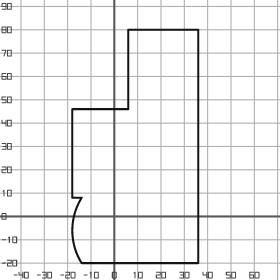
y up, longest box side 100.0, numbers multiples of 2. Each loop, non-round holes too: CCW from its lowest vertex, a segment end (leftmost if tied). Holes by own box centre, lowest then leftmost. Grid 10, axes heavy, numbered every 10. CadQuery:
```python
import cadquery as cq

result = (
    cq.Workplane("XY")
    .moveTo(-14.0, -20.0)
    .lineTo(36.0, -20.0)
    .lineTo(36.0, 80.0)
    .lineTo(6.0, 80.0)
    .lineTo(6.0, 46.0)
    .lineTo(-18.0, 46.0)
    .lineTo(-18.0, 8.0)
    .lineTo(-14.0, 8.0)
    .threePointArc((-18.0, -6.0), (-14.0, -20.0))
    .close()
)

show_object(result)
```